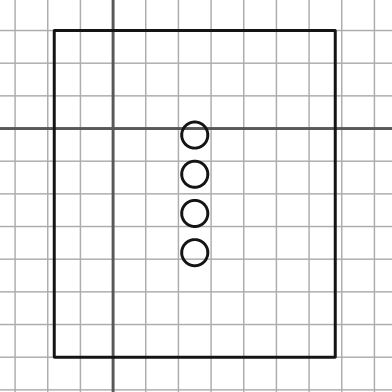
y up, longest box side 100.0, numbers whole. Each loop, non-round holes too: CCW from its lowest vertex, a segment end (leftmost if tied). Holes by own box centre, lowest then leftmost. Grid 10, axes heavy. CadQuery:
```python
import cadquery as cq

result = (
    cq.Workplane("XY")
    .moveTo(-18.0, -70.0)
    .lineTo(68.0, -70.0)
    .lineTo(68.0, 30.0)
    .lineTo(-18.0, 30.0)
    .close()
    .moveTo(25.0, -38.0)
    .circle(4.0)
    .moveTo(25.0, -26.0)
    .circle(4.0)
    .moveTo(25.0, -14.0)
    .circle(4.0)
    .moveTo(25.0, -2.0)
    .circle(4.0)
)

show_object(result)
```